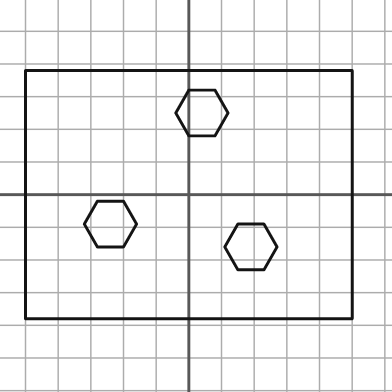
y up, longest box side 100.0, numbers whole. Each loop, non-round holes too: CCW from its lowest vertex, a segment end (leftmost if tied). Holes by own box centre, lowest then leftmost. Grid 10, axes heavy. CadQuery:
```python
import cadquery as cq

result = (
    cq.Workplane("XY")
    .moveTo(-50.0, -38.0)
    .lineTo(50.0, -38.0)
    .lineTo(50.0, 38.0)
    .lineTo(-50.0, 38.0)
    .close()
    .moveTo(15.0, -23.0)
    .lineTo(23.0, -23.0)
    .lineTo(27.0, -16.0)
    .lineTo(23.0, -9.0)
    .lineTo(15.0, -9.0)
    .lineTo(11.0, -16.0)
    .close()
    .moveTo(-28.0, -16.0)
    .lineTo(-20.0, -16.0)
    .lineTo(-16.0, -9.0)
    .lineTo(-20.0, -2.0)
    .lineTo(-28.0, -2.0)
    .lineTo(-32.0, -9.0)
    .close()
    .moveTo(0.0, 18.0)
    .lineTo(8.0, 18.0)
    .lineTo(12.0, 25.0)
    .lineTo(8.0, 32.0)
    .lineTo(0.0, 32.0)
    .lineTo(-4.0, 25.0)
    .close()
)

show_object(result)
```